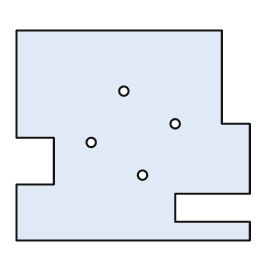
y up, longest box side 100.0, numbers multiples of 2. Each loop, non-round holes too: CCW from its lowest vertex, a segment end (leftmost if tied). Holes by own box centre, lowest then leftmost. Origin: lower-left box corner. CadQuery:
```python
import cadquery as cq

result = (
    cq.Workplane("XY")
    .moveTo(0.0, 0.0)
    .lineTo(100.0, 0.0)
    .lineTo(100.0, 8.0)
    .lineTo(68.0, 8.0)
    .lineTo(68.0, 20.0)
    .lineTo(100.0, 20.0)
    .lineTo(100.0, 50.0)
    .lineTo(88.0, 50.0)
    .lineTo(88.0, 90.0)
    .lineTo(0.0, 90.0)
    .lineTo(0.0, 44.0)
    .lineTo(16.0, 44.0)
    .lineTo(16.0, 24.0)
    .lineTo(0.0, 24.0)
    .close()
    .moveTo(54.0, 28.0)
    .circle(2.0)
    .moveTo(32.0, 42.0)
    .circle(2.0)
    .moveTo(68.0, 50.0)
    .circle(2.0)
    .moveTo(46.0, 64.0)
    .circle(2.0)
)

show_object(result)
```